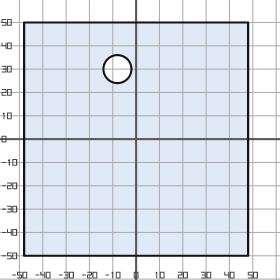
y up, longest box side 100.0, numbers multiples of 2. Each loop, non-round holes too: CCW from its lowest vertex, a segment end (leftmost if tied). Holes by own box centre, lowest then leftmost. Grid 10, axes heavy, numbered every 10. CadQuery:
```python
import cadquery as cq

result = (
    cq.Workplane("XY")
    .moveTo(-48.0, -50.0)
    .lineTo(48.0, -50.0)
    .lineTo(48.0, 50.0)
    .lineTo(-48.0, 50.0)
    .close()
    .moveTo(-8.0, 30.0)
    .circle(6.0)
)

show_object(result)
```